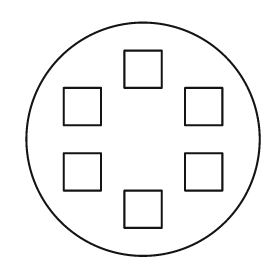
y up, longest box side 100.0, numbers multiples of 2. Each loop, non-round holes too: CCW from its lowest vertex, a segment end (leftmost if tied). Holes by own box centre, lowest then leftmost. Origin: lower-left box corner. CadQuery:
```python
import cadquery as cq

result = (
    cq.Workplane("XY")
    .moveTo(50.0, 50.0)
    .circle(50.0)
    .moveTo(42.0, 12.0)
    .lineTo(58.0, 12.0)
    .lineTo(58.0, 28.0)
    .lineTo(42.0, 28.0)
    .close()
    .moveTo(16.0, 28.0)
    .lineTo(32.0, 28.0)
    .lineTo(32.0, 44.0)
    .lineTo(16.0, 44.0)
    .close()
    .moveTo(68.0, 28.0)
    .lineTo(84.0, 28.0)
    .lineTo(84.0, 44.0)
    .lineTo(68.0, 44.0)
    .close()
    .moveTo(16.0, 56.0)
    .lineTo(32.0, 56.0)
    .lineTo(32.0, 72.0)
    .lineTo(16.0, 72.0)
    .close()
    .moveTo(68.0, 56.0)
    .lineTo(84.0, 56.0)
    .lineTo(84.0, 72.0)
    .lineTo(68.0, 72.0)
    .close()
    .moveTo(42.0, 72.0)
    .lineTo(58.0, 72.0)
    .lineTo(58.0, 88.0)
    .lineTo(42.0, 88.0)
    .close()
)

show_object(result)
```